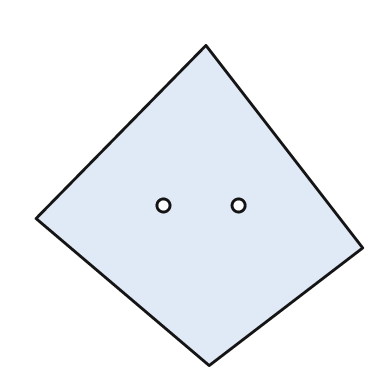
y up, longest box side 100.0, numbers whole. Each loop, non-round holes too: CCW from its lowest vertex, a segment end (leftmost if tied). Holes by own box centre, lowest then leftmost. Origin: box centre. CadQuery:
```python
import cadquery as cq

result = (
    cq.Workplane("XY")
    .moveTo(3.0, -49.0)
    .lineTo(50.0, -13.0)
    .lineTo(2.0, 49.0)
    .lineTo(-50.0, -4.0)
    .close()
    .moveTo(-11.0, 0.0)
    .circle(2.0)
    .moveTo(12.0, 0.0)
    .circle(2.0)
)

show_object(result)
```